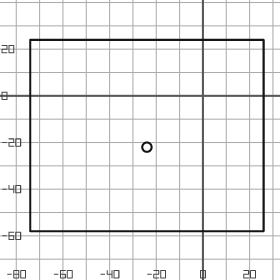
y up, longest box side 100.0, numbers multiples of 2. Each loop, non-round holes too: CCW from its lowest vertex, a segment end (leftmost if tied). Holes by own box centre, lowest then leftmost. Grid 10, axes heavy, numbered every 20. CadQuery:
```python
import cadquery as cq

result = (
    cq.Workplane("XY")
    .moveTo(-74.0, -58.0)
    .lineTo(26.0, -58.0)
    .lineTo(26.0, 24.0)
    .lineTo(-74.0, 24.0)
    .close()
    .moveTo(-24.0, -22.0)
    .circle(2.0)
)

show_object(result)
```